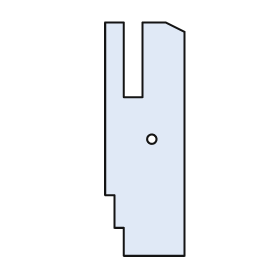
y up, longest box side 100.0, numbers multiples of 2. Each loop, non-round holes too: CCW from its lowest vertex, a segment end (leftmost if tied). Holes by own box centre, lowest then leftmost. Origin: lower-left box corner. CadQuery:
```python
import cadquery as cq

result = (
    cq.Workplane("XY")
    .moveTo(8.0, 0.0)
    .lineTo(34.0, 0.0)
    .lineTo(34.0, 96.0)
    .lineTo(26.0, 100.0)
    .lineTo(16.0, 100.0)
    .lineTo(16.0, 68.0)
    .lineTo(8.0, 68.0)
    .lineTo(8.0, 100.0)
    .lineTo(0.0, 100.0)
    .lineTo(0.0, 26.0)
    .lineTo(4.0, 26.0)
    .lineTo(4.0, 12.0)
    .lineTo(8.0, 12.0)
    .close()
    .moveTo(20.0, 50.0)
    .circle(2.0)
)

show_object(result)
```